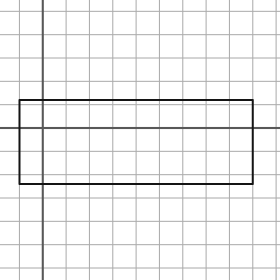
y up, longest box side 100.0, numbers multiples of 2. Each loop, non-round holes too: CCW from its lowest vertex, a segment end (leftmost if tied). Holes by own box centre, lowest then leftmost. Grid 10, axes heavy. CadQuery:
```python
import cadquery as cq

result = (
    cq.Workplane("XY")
    .moveTo(-10.0, -24.0)
    .lineTo(90.0, -24.0)
    .lineTo(90.0, 12.0)
    .lineTo(-10.0, 12.0)
    .close()
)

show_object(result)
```